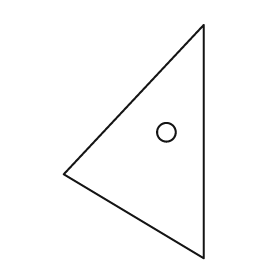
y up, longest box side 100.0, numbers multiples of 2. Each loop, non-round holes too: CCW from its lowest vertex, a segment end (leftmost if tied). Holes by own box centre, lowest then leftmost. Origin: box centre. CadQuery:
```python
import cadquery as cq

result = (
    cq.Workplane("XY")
    .moveTo(30.0, -50.0)
    .lineTo(30.0, 50.0)
    .lineTo(-30.0, -14.0)
    .close()
    .moveTo(14.0, 4.0)
    .circle(4.0)
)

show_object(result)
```